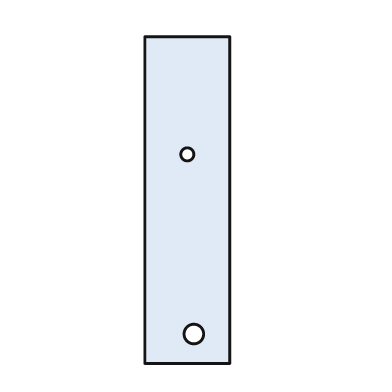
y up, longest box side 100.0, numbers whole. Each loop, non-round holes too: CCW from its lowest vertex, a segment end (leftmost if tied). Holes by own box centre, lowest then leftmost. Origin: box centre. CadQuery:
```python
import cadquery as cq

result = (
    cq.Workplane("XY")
    .moveTo(-13.0, -50.0)
    .lineTo(13.0, -50.0)
    .lineTo(13.0, 50.0)
    .lineTo(-13.0, 50.0)
    .close()
    .moveTo(2.0, -41.0)
    .circle(3.0)
    .moveTo(0.0, 14.0)
    .circle(2.0)
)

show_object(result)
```